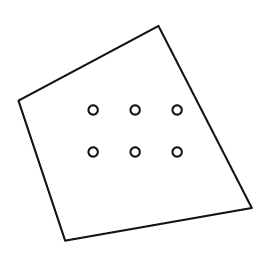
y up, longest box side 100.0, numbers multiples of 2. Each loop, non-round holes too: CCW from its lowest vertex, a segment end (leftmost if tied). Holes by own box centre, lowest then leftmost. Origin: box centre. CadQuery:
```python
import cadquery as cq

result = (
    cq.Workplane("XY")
    .moveTo(-30.0, -46.0)
    .lineTo(50.0, -32.0)
    .lineTo(10.0, 46.0)
    .lineTo(-50.0, 14.0)
    .close()
    .moveTo(-18.0, -8.0)
    .circle(2.0)
    .moveTo(0.0, -8.0)
    .circle(2.0)
    .moveTo(18.0, -8.0)
    .circle(2.0)
    .moveTo(-18.0, 10.0)
    .circle(2.0)
    .moveTo(0.0, 10.0)
    .circle(2.0)
    .moveTo(18.0, 10.0)
    .circle(2.0)
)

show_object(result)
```